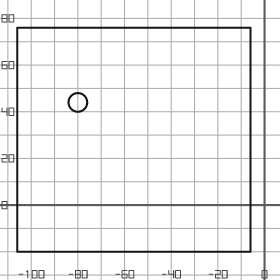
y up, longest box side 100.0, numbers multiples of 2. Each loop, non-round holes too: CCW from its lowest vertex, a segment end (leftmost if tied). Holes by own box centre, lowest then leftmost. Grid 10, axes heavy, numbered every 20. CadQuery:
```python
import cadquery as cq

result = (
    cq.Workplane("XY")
    .moveTo(-106.0, -20.0)
    .lineTo(-6.0, -20.0)
    .lineTo(-6.0, 76.0)
    .lineTo(-106.0, 76.0)
    .close()
    .moveTo(-80.0, 44.0)
    .circle(4.0)
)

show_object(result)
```